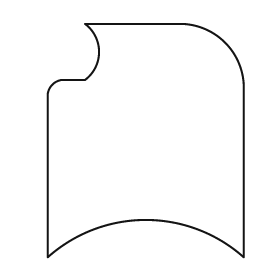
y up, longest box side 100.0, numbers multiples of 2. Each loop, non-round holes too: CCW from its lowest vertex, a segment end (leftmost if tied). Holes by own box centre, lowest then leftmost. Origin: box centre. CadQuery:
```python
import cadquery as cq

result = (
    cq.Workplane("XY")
    .moveTo(-42.0, -50.0)
    .threePointArc((0.0, -34.0), (42.0, -50.0))
    .lineTo(42.0, 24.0)
    .threePointArc((34.0, 42.0), (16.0, 50.0))
    .lineTo(-26.0, 50.0)
    .threePointArc((-20.0, 38.0), (-26.0, 26.0))
    .lineTo(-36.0, 26.0)
    .threePointArc((-40.0, 24.0), (-42.0, 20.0))
    .close()
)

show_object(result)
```